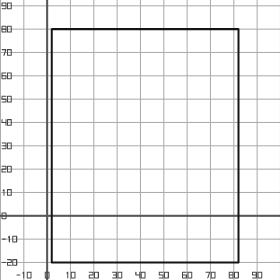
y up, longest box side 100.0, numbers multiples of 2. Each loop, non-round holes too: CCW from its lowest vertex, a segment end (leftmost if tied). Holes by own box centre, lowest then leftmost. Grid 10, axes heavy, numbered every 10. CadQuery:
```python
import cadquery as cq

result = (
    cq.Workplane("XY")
    .moveTo(2.0, -20.0)
    .lineTo(82.0, -20.0)
    .lineTo(82.0, 80.0)
    .lineTo(2.0, 80.0)
    .close()
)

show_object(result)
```